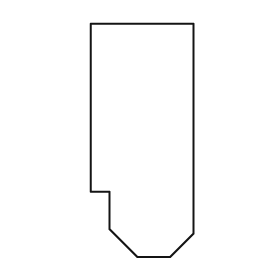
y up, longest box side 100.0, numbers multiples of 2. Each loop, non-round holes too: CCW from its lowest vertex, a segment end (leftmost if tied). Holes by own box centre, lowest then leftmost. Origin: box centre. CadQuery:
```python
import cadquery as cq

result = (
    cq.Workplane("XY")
    .moveTo(-2.0, -50.0)
    .lineTo(12.0, -50.0)
    .lineTo(22.0, -40.0)
    .lineTo(22.0, 50.0)
    .lineTo(-22.0, 50.0)
    .lineTo(-22.0, -22.0)
    .lineTo(-14.0, -22.0)
    .lineTo(-14.0, -38.0)
    .close()
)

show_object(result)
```